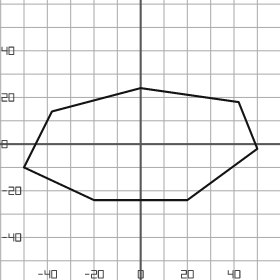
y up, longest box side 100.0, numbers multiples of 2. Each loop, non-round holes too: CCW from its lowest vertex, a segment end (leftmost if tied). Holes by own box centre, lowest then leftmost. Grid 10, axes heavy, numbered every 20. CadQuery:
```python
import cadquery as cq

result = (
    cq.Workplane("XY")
    .moveTo(-20.0, -24.0)
    .lineTo(20.0, -24.0)
    .lineTo(50.0, -2.0)
    .lineTo(42.0, 18.0)
    .lineTo(0.0, 24.0)
    .lineTo(-38.0, 14.0)
    .lineTo(-50.0, -10.0)
    .close()
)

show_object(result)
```